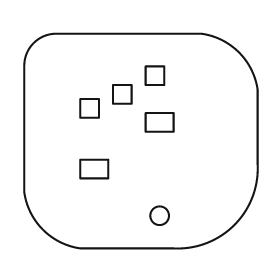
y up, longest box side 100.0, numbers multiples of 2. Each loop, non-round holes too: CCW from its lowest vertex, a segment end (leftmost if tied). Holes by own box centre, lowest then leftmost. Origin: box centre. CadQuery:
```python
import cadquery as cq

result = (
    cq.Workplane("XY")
    .moveTo(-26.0, -46.0)
    .lineTo(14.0, -46.0)
    .threePointArc((40.0, -36.0), (50.0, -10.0))
    .lineTo(50.0, 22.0)
    .threePointArc((42.0, 38.0), (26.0, 46.0))
    .lineTo(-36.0, 46.0)
    .threePointArc((-46.0, 42.0), (-50.0, 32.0))
    .lineTo(-50.0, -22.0)
    .threePointArc((-42.0, -38.0), (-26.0, -46.0))
    .close()
    .moveTo(8.0, -32.0)
    .circle(4.0)
    .moveTo(-26.0, -16.0)
    .lineTo(-14.0, -16.0)
    .lineTo(-14.0, -8.0)
    .lineTo(-26.0, -8.0)
    .close()
    .moveTo(2.0, 4.0)
    .lineTo(14.0, 4.0)
    .lineTo(14.0, 12.0)
    .lineTo(2.0, 12.0)
    .close()
    .moveTo(-26.0, 10.0)
    .lineTo(-18.0, 10.0)
    .lineTo(-18.0, 18.0)
    .lineTo(-26.0, 18.0)
    .close()
    .moveTo(-12.0, 16.0)
    .lineTo(-4.0, 16.0)
    .lineTo(-4.0, 24.0)
    .lineTo(-12.0, 24.0)
    .close()
    .moveTo(2.0, 24.0)
    .lineTo(10.0, 24.0)
    .lineTo(10.0, 32.0)
    .lineTo(2.0, 32.0)
    .close()
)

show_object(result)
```